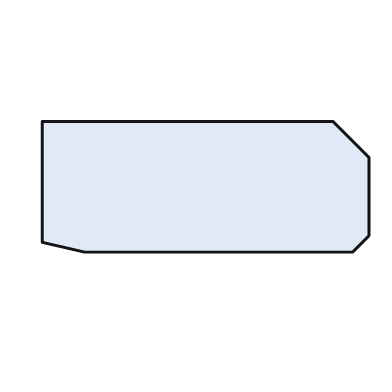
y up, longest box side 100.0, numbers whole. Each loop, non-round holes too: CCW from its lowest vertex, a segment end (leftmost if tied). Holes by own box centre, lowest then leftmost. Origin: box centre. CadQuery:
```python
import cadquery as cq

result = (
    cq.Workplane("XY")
    .moveTo(-37.0, -20.0)
    .lineTo(45.0, -20.0)
    .lineTo(50.0, -15.0)
    .lineTo(50.0, 9.0)
    .lineTo(39.0, 20.0)
    .lineTo(-50.0, 20.0)
    .lineTo(-50.0, -17.0)
    .close()
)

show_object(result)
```